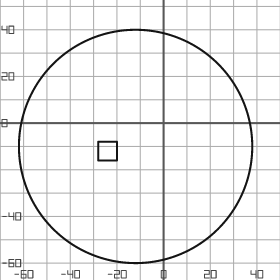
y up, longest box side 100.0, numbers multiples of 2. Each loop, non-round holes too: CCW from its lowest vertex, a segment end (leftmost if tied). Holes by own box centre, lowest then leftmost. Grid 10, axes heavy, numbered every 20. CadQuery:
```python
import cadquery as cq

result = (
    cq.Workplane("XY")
    .moveTo(-12.0, -10.0)
    .circle(50.0)
    .moveTo(-28.0, -16.0)
    .lineTo(-20.0, -16.0)
    .lineTo(-20.0, -8.0)
    .lineTo(-28.0, -8.0)
    .close()
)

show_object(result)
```